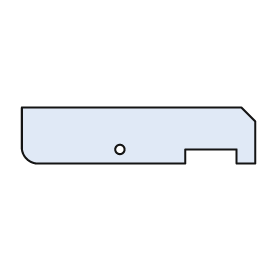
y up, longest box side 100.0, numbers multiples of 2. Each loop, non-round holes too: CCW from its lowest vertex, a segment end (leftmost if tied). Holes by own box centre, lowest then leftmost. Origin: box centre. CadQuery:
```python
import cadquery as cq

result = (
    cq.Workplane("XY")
    .moveTo(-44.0, -12.0)
    .lineTo(20.0, -12.0)
    .lineTo(20.0, -6.0)
    .lineTo(42.0, -6.0)
    .lineTo(42.0, -12.0)
    .lineTo(50.0, -12.0)
    .lineTo(50.0, 6.0)
    .lineTo(44.0, 12.0)
    .lineTo(-50.0, 12.0)
    .lineTo(-50.0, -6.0)
    .threePointArc((-48.0, -10.0), (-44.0, -12.0))
    .close()
    .moveTo(-8.0, -6.0)
    .circle(2.0)
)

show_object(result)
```